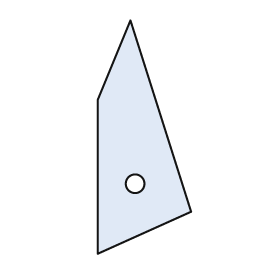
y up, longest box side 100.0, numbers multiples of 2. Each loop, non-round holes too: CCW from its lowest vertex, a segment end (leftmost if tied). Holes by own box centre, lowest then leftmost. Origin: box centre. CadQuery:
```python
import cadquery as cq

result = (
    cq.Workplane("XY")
    .moveTo(-20.0, -50.0)
    .lineTo(20.0, -32.0)
    .lineTo(-6.0, 50.0)
    .lineTo(-20.0, 16.0)
    .close()
    .moveTo(-4.0, -20.0)
    .circle(4.0)
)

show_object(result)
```